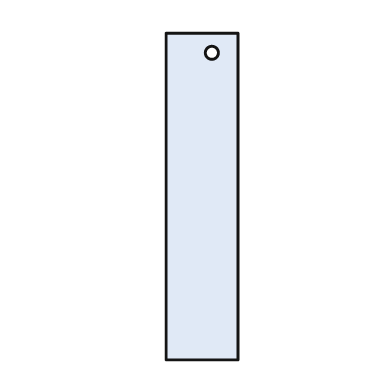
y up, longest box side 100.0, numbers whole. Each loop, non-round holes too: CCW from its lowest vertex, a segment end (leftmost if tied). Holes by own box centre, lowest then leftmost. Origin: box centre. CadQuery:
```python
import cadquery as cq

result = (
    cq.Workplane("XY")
    .moveTo(-11.0, -50.0)
    .lineTo(11.0, -50.0)
    .lineTo(11.0, 50.0)
    .lineTo(-11.0, 50.0)
    .close()
    .moveTo(3.0, 44.0)
    .circle(2.0)
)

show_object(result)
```